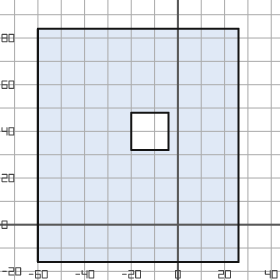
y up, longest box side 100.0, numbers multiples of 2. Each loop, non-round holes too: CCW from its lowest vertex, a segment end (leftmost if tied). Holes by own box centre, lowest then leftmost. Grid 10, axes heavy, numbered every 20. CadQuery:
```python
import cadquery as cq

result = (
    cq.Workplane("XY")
    .moveTo(-60.0, -16.0)
    .lineTo(26.0, -16.0)
    .lineTo(26.0, 84.0)
    .lineTo(-60.0, 84.0)
    .close()
    .moveTo(-20.0, 32.0)
    .lineTo(-4.0, 32.0)
    .lineTo(-4.0, 48.0)
    .lineTo(-20.0, 48.0)
    .close()
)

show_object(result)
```